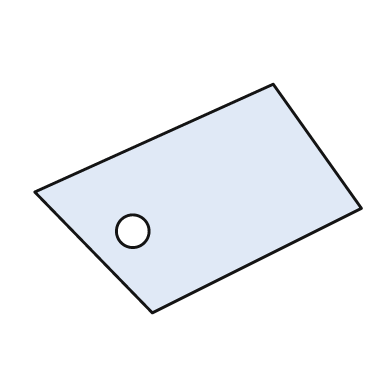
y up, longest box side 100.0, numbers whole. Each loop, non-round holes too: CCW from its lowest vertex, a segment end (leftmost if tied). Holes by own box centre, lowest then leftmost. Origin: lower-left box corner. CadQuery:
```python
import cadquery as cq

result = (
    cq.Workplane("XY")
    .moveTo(36.0, 0.0)
    .lineTo(100.0, 32.0)
    .lineTo(73.0, 70.0)
    .lineTo(0.0, 37.0)
    .close()
    .moveTo(30.0, 25.0)
    .circle(5.0)
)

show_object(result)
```